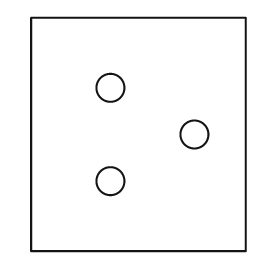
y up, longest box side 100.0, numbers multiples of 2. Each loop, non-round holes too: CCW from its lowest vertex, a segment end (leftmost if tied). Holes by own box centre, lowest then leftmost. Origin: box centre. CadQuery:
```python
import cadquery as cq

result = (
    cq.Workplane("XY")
    .moveTo(-46.0, -50.0)
    .lineTo(46.0, -50.0)
    .lineTo(46.0, 50.0)
    .lineTo(-46.0, 50.0)
    .close()
    .moveTo(-12.0, -20.0)
    .circle(6.0)
    .moveTo(24.0, 0.0)
    .circle(6.0)
    .moveTo(-12.0, 20.0)
    .circle(6.0)
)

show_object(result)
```